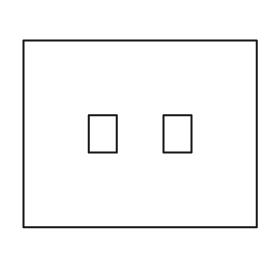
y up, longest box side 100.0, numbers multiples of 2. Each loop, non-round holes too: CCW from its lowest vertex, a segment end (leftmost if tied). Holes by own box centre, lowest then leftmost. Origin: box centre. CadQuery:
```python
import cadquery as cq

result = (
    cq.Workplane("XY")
    .moveTo(-50.0, -40.0)
    .lineTo(50.0, -40.0)
    .lineTo(50.0, 40.0)
    .lineTo(-50.0, 40.0)
    .close()
    .moveTo(-22.0, -8.0)
    .lineTo(-10.0, -8.0)
    .lineTo(-10.0, 8.0)
    .lineTo(-22.0, 8.0)
    .close()
    .moveTo(10.0, -8.0)
    .lineTo(22.0, -8.0)
    .lineTo(22.0, 8.0)
    .lineTo(10.0, 8.0)
    .close()
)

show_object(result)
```